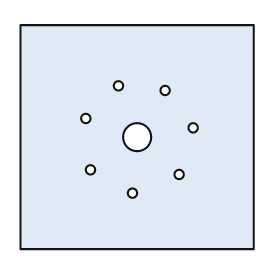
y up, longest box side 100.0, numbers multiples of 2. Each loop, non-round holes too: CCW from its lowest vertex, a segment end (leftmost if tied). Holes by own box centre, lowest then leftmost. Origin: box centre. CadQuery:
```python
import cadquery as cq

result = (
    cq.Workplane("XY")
    .moveTo(-50.0, -48.0)
    .lineTo(50.0, -48.0)
    .lineTo(50.0, 48.0)
    .lineTo(-50.0, 48.0)
    .close()
    .moveTo(-2.0, -24.0)
    .circle(2.0)
    .moveTo(18.0, -16.0)
    .circle(2.0)
    .moveTo(-20.0, -14.0)
    .circle(2.0)
    .moveTo(0.0, 0.0)
    .circle(6.0)
    .moveTo(24.0, 4.0)
    .circle(2.0)
    .moveTo(-22.0, 8.0)
    .circle(2.0)
    .moveTo(12.0, 20.0)
    .circle(2.0)
    .moveTo(-8.0, 22.0)
    .circle(2.0)
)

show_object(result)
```